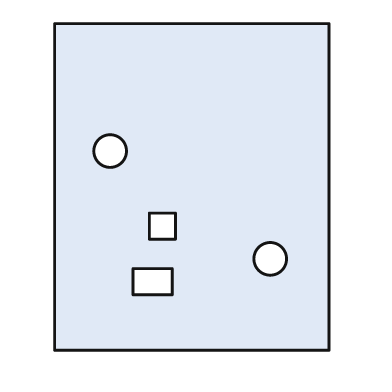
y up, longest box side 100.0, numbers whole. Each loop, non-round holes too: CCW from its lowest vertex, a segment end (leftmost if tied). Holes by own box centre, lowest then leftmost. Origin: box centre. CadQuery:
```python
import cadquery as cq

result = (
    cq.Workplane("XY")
    .moveTo(-42.0, -50.0)
    .lineTo(42.0, -50.0)
    .lineTo(42.0, 50.0)
    .lineTo(-42.0, 50.0)
    .close()
    .moveTo(-18.0, -33.0)
    .lineTo(-6.0, -33.0)
    .lineTo(-6.0, -25.0)
    .lineTo(-18.0, -25.0)
    .close()
    .moveTo(24.0, -22.0)
    .circle(5.0)
    .moveTo(-13.0, -16.0)
    .lineTo(-5.0, -16.0)
    .lineTo(-5.0, -8.0)
    .lineTo(-13.0, -8.0)
    .close()
    .moveTo(-25.0, 11.0)
    .circle(5.0)
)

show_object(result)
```